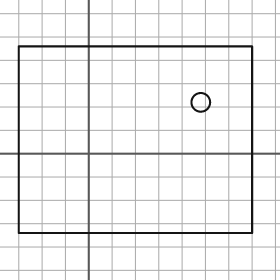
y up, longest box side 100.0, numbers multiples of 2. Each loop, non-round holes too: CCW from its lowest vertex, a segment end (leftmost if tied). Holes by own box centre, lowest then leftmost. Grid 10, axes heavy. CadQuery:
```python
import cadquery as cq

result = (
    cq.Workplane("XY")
    .moveTo(-30.0, -34.0)
    .lineTo(70.0, -34.0)
    .lineTo(70.0, 46.0)
    .lineTo(-30.0, 46.0)
    .close()
    .moveTo(48.0, 22.0)
    .circle(4.0)
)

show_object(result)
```